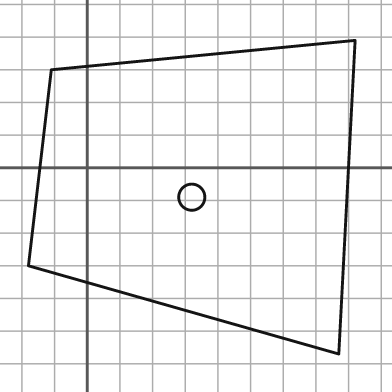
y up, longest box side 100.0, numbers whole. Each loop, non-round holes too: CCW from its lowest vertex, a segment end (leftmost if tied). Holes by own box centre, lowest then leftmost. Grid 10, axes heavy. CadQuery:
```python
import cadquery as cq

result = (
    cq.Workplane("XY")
    .moveTo(77.0, -57.0)
    .lineTo(82.0, 39.0)
    .lineTo(-11.0, 30.0)
    .lineTo(-18.0, -30.0)
    .close()
    .moveTo(32.0, -9.0)
    .circle(4.0)
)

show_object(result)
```